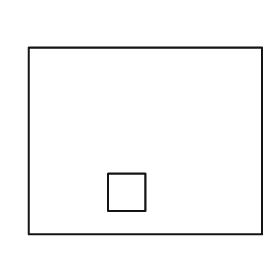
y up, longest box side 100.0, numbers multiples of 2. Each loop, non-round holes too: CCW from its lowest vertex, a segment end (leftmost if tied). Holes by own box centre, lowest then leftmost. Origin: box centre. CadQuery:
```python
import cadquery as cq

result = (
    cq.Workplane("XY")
    .moveTo(-50.0, -40.0)
    .lineTo(50.0, -40.0)
    .lineTo(50.0, 40.0)
    .lineTo(-50.0, 40.0)
    .close()
    .moveTo(-16.0, -30.0)
    .lineTo(0.0, -30.0)
    .lineTo(0.0, -14.0)
    .lineTo(-16.0, -14.0)
    .close()
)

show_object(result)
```